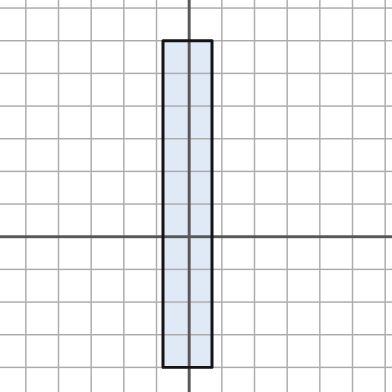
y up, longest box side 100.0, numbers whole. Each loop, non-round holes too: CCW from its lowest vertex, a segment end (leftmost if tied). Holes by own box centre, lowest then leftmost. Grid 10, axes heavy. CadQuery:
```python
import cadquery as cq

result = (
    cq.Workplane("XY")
    .moveTo(-8.0, -40.0)
    .lineTo(7.0, -40.0)
    .lineTo(7.0, 60.0)
    .lineTo(-8.0, 60.0)
    .close()
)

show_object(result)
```